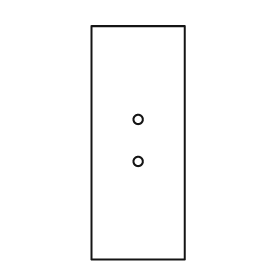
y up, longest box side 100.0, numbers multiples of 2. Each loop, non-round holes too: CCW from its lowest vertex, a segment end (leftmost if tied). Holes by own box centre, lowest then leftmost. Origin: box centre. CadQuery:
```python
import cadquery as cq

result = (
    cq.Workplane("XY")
    .moveTo(-20.0, -50.0)
    .lineTo(20.0, -50.0)
    .lineTo(20.0, 50.0)
    .lineTo(-20.0, 50.0)
    .close()
    .moveTo(0.0, -8.0)
    .circle(2.0)
    .moveTo(0.0, 10.0)
    .circle(2.0)
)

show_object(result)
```